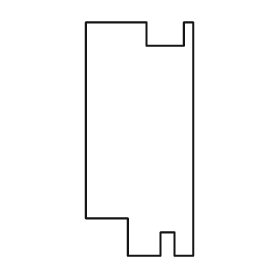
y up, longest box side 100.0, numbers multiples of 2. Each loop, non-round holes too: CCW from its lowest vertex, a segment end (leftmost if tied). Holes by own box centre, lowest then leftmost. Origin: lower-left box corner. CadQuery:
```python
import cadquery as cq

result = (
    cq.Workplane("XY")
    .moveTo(18.0, 0.0)
    .lineTo(32.0, 0.0)
    .lineTo(32.0, 10.0)
    .lineTo(38.0, 10.0)
    .lineTo(38.0, 0.0)
    .lineTo(46.0, 0.0)
    .lineTo(46.0, 100.0)
    .lineTo(42.0, 100.0)
    .lineTo(42.0, 90.0)
    .lineTo(26.0, 90.0)
    .lineTo(26.0, 100.0)
    .lineTo(0.0, 100.0)
    .lineTo(0.0, 16.0)
    .lineTo(18.0, 16.0)
    .close()
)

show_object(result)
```